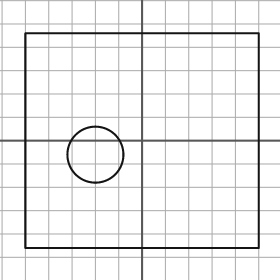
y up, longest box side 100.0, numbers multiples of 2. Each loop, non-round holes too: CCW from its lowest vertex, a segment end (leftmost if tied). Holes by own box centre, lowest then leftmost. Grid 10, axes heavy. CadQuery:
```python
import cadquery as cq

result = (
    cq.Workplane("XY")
    .moveTo(-50.0, -46.0)
    .lineTo(50.0, -46.0)
    .lineTo(50.0, 46.0)
    .lineTo(-50.0, 46.0)
    .close()
    .moveTo(-20.0, -6.0)
    .circle(12.0)
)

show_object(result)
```